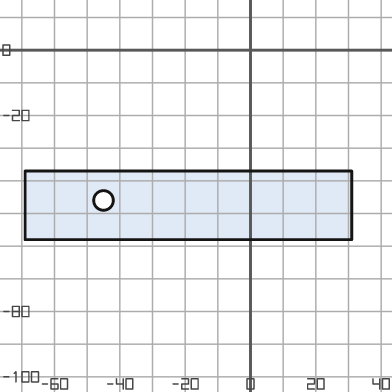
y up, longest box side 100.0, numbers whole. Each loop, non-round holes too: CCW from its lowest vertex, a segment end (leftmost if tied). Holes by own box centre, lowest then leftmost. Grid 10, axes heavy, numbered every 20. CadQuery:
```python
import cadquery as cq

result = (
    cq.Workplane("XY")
    .moveTo(-69.0, -58.0)
    .lineTo(31.0, -58.0)
    .lineTo(31.0, -37.0)
    .lineTo(-69.0, -37.0)
    .close()
    .moveTo(-45.0, -46.0)
    .circle(3.0)
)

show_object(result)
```